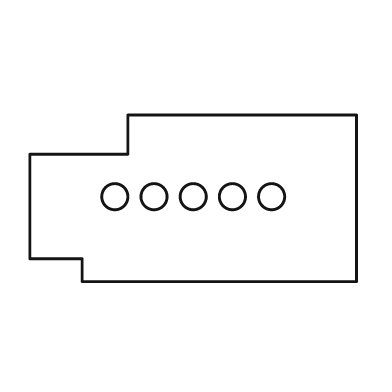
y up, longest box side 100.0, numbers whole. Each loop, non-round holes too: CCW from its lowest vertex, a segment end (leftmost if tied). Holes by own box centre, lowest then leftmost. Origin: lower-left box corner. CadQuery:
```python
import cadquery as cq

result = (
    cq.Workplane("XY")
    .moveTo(16.0, 0.0)
    .lineTo(100.0, 0.0)
    .lineTo(100.0, 51.0)
    .lineTo(30.0, 51.0)
    .lineTo(30.0, 39.0)
    .lineTo(0.0, 39.0)
    .lineTo(0.0, 7.0)
    .lineTo(16.0, 7.0)
    .close()
    .moveTo(26.0, 26.0)
    .circle(4.0)
    .moveTo(38.0, 26.0)
    .circle(4.0)
    .moveTo(50.0, 26.0)
    .circle(4.0)
    .moveTo(62.0, 26.0)
    .circle(4.0)
    .moveTo(74.0, 26.0)
    .circle(4.0)
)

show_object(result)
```